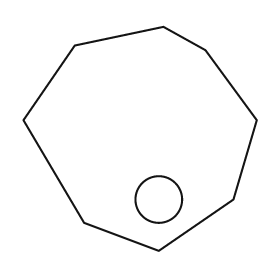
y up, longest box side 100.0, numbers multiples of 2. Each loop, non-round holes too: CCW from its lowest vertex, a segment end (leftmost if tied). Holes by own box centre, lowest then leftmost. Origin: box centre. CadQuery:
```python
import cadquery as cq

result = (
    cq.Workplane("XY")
    .moveTo(8.0, -48.0)
    .lineTo(40.0, -26.0)
    .lineTo(50.0, 8.0)
    .lineTo(28.0, 38.0)
    .lineTo(10.0, 48.0)
    .lineTo(-28.0, 40.0)
    .lineTo(-50.0, 8.0)
    .lineTo(-24.0, -36.0)
    .close()
    .moveTo(8.0, -26.0)
    .circle(10.0)
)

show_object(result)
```